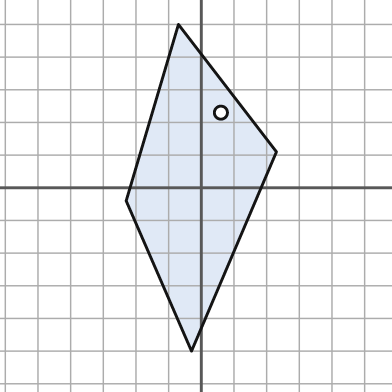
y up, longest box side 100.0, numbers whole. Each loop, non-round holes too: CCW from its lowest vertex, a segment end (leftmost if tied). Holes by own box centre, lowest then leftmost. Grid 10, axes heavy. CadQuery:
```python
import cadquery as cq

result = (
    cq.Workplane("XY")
    .moveTo(-3.0, -50.0)
    .lineTo(23.0, 11.0)
    .lineTo(-7.0, 50.0)
    .lineTo(-23.0, -4.0)
    .close()
    .moveTo(6.0, 23.0)
    .circle(2.0)
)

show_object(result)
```